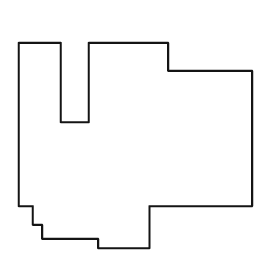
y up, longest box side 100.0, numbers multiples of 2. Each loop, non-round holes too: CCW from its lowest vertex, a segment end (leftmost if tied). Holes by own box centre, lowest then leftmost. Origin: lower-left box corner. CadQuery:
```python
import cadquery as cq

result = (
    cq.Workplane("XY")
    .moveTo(34.0, 0.0)
    .lineTo(56.0, 0.0)
    .lineTo(56.0, 18.0)
    .lineTo(100.0, 18.0)
    .lineTo(100.0, 76.0)
    .lineTo(64.0, 76.0)
    .lineTo(64.0, 88.0)
    .lineTo(30.0, 88.0)
    .lineTo(30.0, 54.0)
    .lineTo(18.0, 54.0)
    .lineTo(18.0, 88.0)
    .lineTo(0.0, 88.0)
    .lineTo(0.0, 18.0)
    .lineTo(6.0, 18.0)
    .lineTo(6.0, 10.0)
    .lineTo(10.0, 10.0)
    .lineTo(10.0, 4.0)
    .lineTo(34.0, 4.0)
    .close()
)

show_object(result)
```